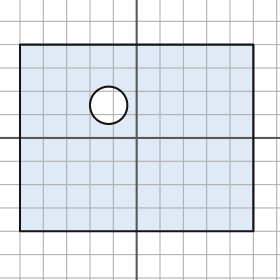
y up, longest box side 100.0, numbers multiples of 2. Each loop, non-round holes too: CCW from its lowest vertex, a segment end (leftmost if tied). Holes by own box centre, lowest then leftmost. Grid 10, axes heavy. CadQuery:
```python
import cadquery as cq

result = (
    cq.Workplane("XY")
    .moveTo(-50.0, -40.0)
    .lineTo(50.0, -40.0)
    .lineTo(50.0, 40.0)
    .lineTo(-50.0, 40.0)
    .close()
    .moveTo(-12.0, 14.0)
    .circle(8.0)
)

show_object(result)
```